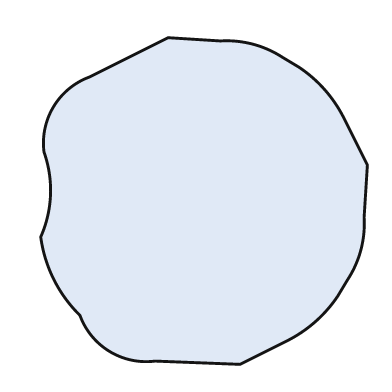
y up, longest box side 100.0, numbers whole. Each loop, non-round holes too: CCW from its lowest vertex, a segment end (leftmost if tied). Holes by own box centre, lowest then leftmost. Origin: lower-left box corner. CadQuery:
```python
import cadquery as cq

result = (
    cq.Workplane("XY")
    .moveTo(61.0, 0.0)
    .lineTo(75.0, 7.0)
    .threePointArc((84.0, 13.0), (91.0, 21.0))
    .lineTo(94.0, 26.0)
    .threePointArc((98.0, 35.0), (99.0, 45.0))
    .lineTo(100.0, 61.0)
    .lineTo(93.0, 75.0)
    .threePointArc((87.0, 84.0), (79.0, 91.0))
    .lineTo(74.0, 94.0)
    .threePointArc((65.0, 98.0), (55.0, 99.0))
    .lineTo(39.0, 100.0)
    .lineTo(15.0, 88.0)
    .threePointArc((4.0, 79.0), (1.0, 65.0))
    .threePointArc((3.0, 52.0), (0.0, 39.0))
    .threePointArc((4.0, 26.0), (12.0, 15.0))
    .threePointArc((21.0, 4.0), (35.0, 1.0))
    .close()
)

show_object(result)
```